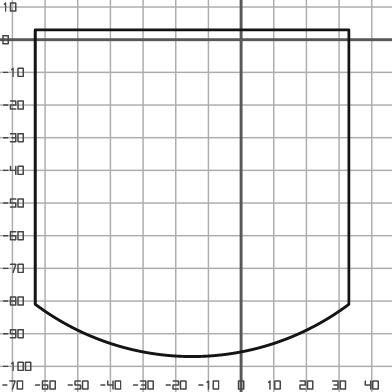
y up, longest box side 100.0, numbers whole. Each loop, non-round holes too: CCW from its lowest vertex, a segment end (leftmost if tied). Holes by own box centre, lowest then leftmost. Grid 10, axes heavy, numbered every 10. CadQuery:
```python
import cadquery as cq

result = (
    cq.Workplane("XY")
    .moveTo(-63.0, -81.0)
    .threePointArc((-15.0, -97.0), (33.0, -81.0))
    .lineTo(33.0, 3.0)
    .lineTo(-63.0, 3.0)
    .close()
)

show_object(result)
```